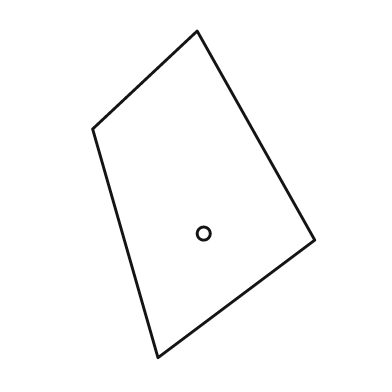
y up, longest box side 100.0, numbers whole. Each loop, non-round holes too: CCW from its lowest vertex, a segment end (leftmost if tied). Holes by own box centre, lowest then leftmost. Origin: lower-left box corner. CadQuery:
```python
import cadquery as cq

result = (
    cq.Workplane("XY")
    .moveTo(20.0, 0.0)
    .lineTo(68.0, 36.0)
    .lineTo(32.0, 100.0)
    .lineTo(0.0, 70.0)
    .close()
    .moveTo(34.0, 38.0)
    .circle(2.0)
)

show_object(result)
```